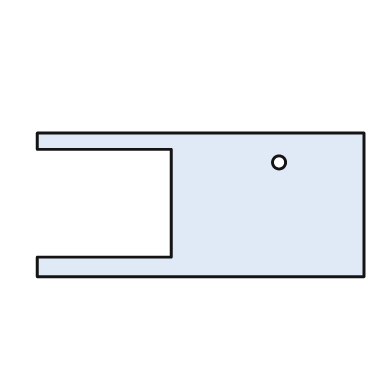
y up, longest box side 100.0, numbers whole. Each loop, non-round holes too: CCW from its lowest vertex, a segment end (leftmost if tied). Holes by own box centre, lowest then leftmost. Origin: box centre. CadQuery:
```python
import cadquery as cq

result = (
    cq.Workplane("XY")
    .moveTo(-50.0, -22.0)
    .lineTo(50.0, -22.0)
    .lineTo(50.0, 22.0)
    .lineTo(-50.0, 22.0)
    .lineTo(-50.0, 17.0)
    .lineTo(-9.0, 17.0)
    .lineTo(-9.0, -16.0)
    .lineTo(-50.0, -16.0)
    .close()
    .moveTo(24.0, 13.0)
    .circle(2.0)
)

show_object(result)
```